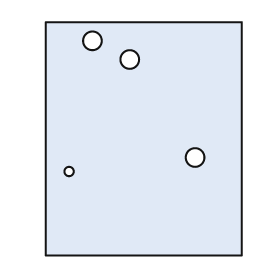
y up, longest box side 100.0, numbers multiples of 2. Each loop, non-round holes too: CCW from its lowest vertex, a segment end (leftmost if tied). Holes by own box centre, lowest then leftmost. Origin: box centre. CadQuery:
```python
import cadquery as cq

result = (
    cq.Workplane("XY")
    .moveTo(-42.0, -50.0)
    .lineTo(42.0, -50.0)
    .lineTo(42.0, 50.0)
    .lineTo(-42.0, 50.0)
    .close()
    .moveTo(-32.0, -14.0)
    .circle(2.0)
    .moveTo(22.0, -8.0)
    .circle(4.0)
    .moveTo(-6.0, 34.0)
    .circle(4.0)
    .moveTo(-22.0, 42.0)
    .circle(4.0)
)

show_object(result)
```